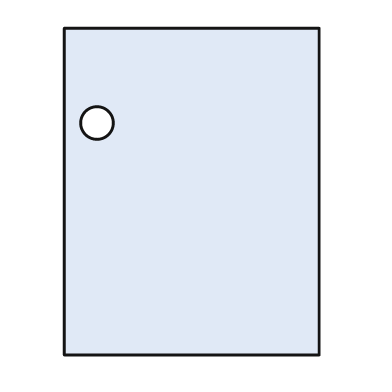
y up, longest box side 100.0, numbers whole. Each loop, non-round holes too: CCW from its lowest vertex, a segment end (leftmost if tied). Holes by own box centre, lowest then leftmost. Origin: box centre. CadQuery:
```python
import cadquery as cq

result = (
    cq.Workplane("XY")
    .moveTo(-39.0, -50.0)
    .lineTo(39.0, -50.0)
    .lineTo(39.0, 50.0)
    .lineTo(-39.0, 50.0)
    .close()
    .moveTo(-29.0, 21.0)
    .circle(5.0)
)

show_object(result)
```